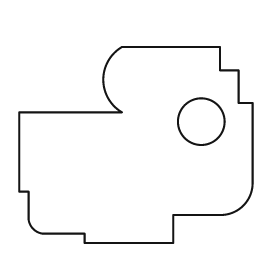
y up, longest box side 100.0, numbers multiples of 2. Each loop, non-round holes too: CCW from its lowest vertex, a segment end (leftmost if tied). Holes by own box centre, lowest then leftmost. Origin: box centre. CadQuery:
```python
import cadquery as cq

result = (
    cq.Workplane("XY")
    .moveTo(-22.0, -42.0)
    .lineTo(16.0, -42.0)
    .lineTo(16.0, -30.0)
    .lineTo(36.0, -30.0)
    .threePointArc((46.0, -26.0), (50.0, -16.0))
    .lineTo(50.0, 18.0)
    .lineTo(44.0, 18.0)
    .lineTo(44.0, 32.0)
    .lineTo(36.0, 32.0)
    .lineTo(36.0, 42.0)
    .lineTo(-6.0, 42.0)
    .threePointArc((-14.0, 28.0), (-6.0, 14.0))
    .lineTo(-50.0, 14.0)
    .lineTo(-50.0, -20.0)
    .lineTo(-46.0, -20.0)
    .lineTo(-46.0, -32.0)
    .threePointArc((-44.0, -36.0), (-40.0, -38.0))
    .lineTo(-22.0, -38.0)
    .close()
    .moveTo(28.0, 10.0)
    .circle(10.0)
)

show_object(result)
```